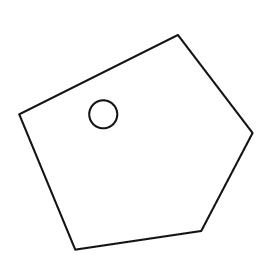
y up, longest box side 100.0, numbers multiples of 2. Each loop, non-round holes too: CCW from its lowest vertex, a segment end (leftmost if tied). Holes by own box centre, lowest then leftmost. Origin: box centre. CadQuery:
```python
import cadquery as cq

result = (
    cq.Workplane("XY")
    .moveTo(-26.0, -46.0)
    .lineTo(28.0, -38.0)
    .lineTo(50.0, 4.0)
    .lineTo(18.0, 46.0)
    .lineTo(-50.0, 12.0)
    .close()
    .moveTo(-14.0, 12.0)
    .circle(6.0)
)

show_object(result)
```